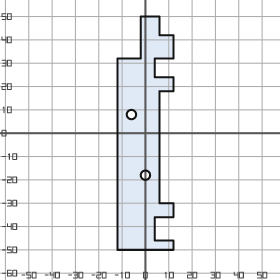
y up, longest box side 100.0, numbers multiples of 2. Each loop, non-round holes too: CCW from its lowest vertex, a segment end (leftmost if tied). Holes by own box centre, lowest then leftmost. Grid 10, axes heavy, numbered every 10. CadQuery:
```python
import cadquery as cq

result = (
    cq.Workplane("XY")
    .moveTo(-12.0, -50.0)
    .lineTo(12.0, -50.0)
    .lineTo(12.0, -46.0)
    .lineTo(4.0, -46.0)
    .lineTo(4.0, -36.0)
    .lineTo(12.0, -36.0)
    .lineTo(12.0, -30.0)
    .lineTo(6.0, -30.0)
    .lineTo(6.0, 18.0)
    .lineTo(12.0, 18.0)
    .lineTo(12.0, 24.0)
    .lineTo(4.0, 24.0)
    .lineTo(4.0, 32.0)
    .lineTo(12.0, 32.0)
    .lineTo(12.0, 42.0)
    .lineTo(6.0, 42.0)
    .lineTo(6.0, 50.0)
    .lineTo(-2.0, 50.0)
    .lineTo(-2.0, 32.0)
    .lineTo(-12.0, 32.0)
    .close()
    .moveTo(0.0, -18.0)
    .circle(2.0)
    .moveTo(-6.0, 8.0)
    .circle(2.0)
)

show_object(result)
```